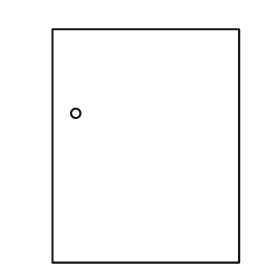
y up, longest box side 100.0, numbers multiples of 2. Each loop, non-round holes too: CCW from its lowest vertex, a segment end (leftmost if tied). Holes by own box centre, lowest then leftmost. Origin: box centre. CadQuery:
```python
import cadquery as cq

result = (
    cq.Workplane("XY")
    .moveTo(-40.0, -50.0)
    .lineTo(40.0, -50.0)
    .lineTo(40.0, 50.0)
    .lineTo(-40.0, 50.0)
    .close()
    .moveTo(-30.0, 14.0)
    .circle(2.0)
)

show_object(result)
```